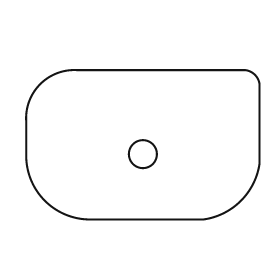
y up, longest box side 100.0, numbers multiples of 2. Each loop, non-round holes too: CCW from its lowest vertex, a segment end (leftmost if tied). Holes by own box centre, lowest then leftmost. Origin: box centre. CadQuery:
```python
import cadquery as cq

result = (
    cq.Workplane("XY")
    .moveTo(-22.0, -32.0)
    .lineTo(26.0, -32.0)
    .threePointArc((42.0, -24.0), (50.0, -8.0))
    .lineTo(50.0, 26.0)
    .threePointArc((48.0, 30.0), (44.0, 32.0))
    .lineTo(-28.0, 32.0)
    .threePointArc((-44.0, 26.0), (-50.0, 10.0))
    .lineTo(-50.0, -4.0)
    .threePointArc((-42.0, -24.0), (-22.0, -32.0))
    .close()
    .moveTo(0.0, -4.0)
    .circle(6.0)
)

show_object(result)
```